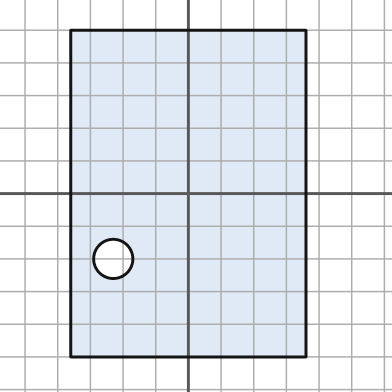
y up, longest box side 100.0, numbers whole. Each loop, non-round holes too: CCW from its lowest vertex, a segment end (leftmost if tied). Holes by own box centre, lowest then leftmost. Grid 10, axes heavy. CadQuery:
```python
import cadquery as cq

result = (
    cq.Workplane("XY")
    .moveTo(-36.0, -50.0)
    .lineTo(36.0, -50.0)
    .lineTo(36.0, 50.0)
    .lineTo(-36.0, 50.0)
    .close()
    .moveTo(-23.0, -20.0)
    .circle(6.0)
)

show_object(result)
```